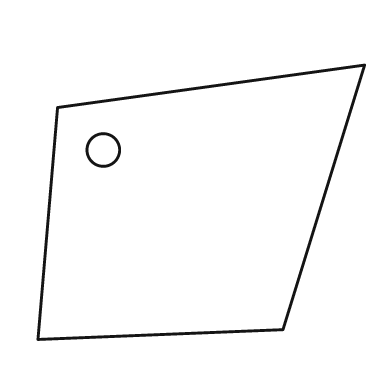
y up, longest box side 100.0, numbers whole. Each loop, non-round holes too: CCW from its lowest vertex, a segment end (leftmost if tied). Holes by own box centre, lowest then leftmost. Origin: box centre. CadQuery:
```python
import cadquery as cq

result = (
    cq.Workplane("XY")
    .moveTo(-50.0, -42.0)
    .lineTo(25.0, -39.0)
    .lineTo(50.0, 42.0)
    .lineTo(-44.0, 29.0)
    .close()
    .moveTo(-30.0, 16.0)
    .circle(5.0)
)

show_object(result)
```